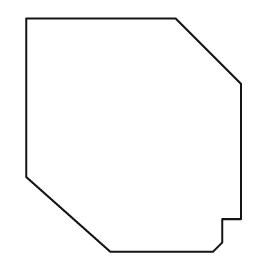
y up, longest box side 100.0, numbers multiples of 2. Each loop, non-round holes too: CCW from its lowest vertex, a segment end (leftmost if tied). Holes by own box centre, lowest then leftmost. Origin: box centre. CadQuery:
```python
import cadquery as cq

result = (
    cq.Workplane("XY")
    .moveTo(-10.0, -50.0)
    .lineTo(34.0, -50.0)
    .lineTo(38.0, -46.0)
    .lineTo(38.0, -36.0)
    .lineTo(46.0, -36.0)
    .lineTo(46.0, 22.0)
    .lineTo(18.0, 50.0)
    .lineTo(-46.0, 50.0)
    .lineTo(-46.0, -18.0)
    .close()
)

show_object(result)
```